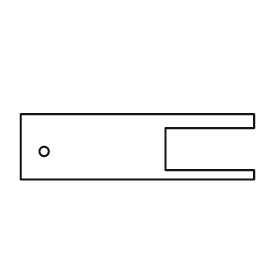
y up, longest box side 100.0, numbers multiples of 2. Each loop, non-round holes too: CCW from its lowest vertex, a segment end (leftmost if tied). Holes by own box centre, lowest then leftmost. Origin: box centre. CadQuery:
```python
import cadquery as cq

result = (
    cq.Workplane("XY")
    .moveTo(-50.0, -14.0)
    .lineTo(50.0, -14.0)
    .lineTo(50.0, -10.0)
    .lineTo(12.0, -10.0)
    .lineTo(12.0, 8.0)
    .lineTo(50.0, 8.0)
    .lineTo(50.0, 14.0)
    .lineTo(-50.0, 14.0)
    .close()
    .moveTo(-40.0, -2.0)
    .circle(2.0)
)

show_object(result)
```